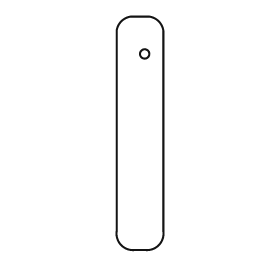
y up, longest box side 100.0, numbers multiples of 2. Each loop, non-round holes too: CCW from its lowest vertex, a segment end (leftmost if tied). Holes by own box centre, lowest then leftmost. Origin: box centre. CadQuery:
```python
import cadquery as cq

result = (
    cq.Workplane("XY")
    .moveTo(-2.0, -50.0)
    .lineTo(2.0, -50.0)
    .threePointArc((8.0, -48.0), (10.0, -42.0))
    .lineTo(10.0, 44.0)
    .threePointArc((8.0, 48.0), (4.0, 50.0))
    .lineTo(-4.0, 50.0)
    .threePointArc((-8.0, 48.0), (-10.0, 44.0))
    .lineTo(-10.0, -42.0)
    .threePointArc((-8.0, -48.0), (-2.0, -50.0))
    .close()
    .moveTo(2.0, 34.0)
    .circle(2.0)
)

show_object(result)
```